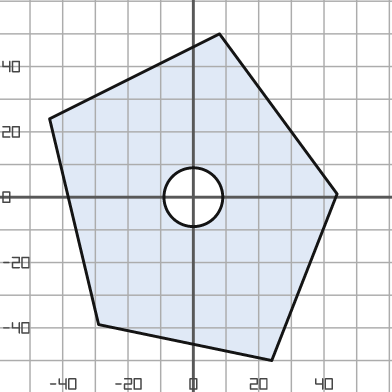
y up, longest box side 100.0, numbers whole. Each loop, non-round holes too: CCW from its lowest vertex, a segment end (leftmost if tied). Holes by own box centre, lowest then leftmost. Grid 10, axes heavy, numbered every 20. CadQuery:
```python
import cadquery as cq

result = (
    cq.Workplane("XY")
    .moveTo(24.0, -50.0)
    .lineTo(44.0, 1.0)
    .lineTo(8.0, 50.0)
    .lineTo(-44.0, 24.0)
    .lineTo(-29.0, -39.0)
    .close()
    .moveTo(0.0, 0.0)
    .circle(9.0)
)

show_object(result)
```